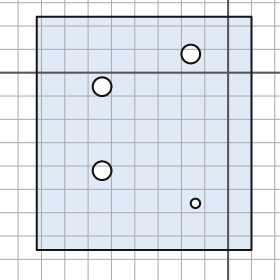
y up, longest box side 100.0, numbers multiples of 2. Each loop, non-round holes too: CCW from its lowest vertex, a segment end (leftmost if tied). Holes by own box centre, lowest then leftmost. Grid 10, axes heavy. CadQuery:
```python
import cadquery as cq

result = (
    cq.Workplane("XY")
    .moveTo(-82.0, -76.0)
    .lineTo(10.0, -76.0)
    .lineTo(10.0, 24.0)
    .lineTo(-82.0, 24.0)
    .close()
    .moveTo(-14.0, -56.0)
    .circle(2.0)
    .moveTo(-54.0, -42.0)
    .circle(4.0)
    .moveTo(-54.0, -6.0)
    .circle(4.0)
    .moveTo(-16.0, 8.0)
    .circle(4.0)
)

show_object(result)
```